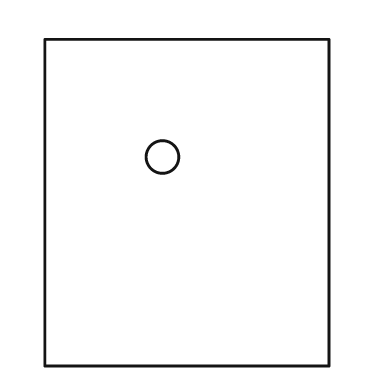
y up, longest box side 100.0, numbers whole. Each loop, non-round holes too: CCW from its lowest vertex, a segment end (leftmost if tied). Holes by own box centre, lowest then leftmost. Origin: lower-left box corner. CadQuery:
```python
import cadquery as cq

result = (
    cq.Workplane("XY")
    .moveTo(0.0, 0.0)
    .lineTo(87.0, 0.0)
    .lineTo(87.0, 100.0)
    .lineTo(0.0, 100.0)
    .close()
    .moveTo(36.0, 64.0)
    .circle(5.0)
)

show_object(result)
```